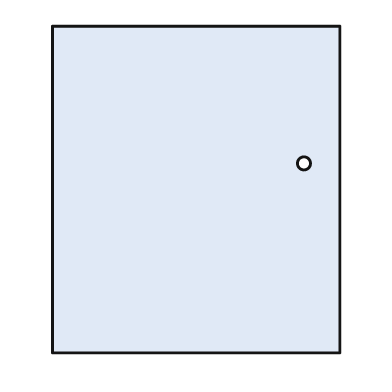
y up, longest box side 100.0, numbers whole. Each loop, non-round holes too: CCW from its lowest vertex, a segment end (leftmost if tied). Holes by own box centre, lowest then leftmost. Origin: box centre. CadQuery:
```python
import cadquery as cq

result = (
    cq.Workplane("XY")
    .moveTo(-44.0, -50.0)
    .lineTo(44.0, -50.0)
    .lineTo(44.0, 50.0)
    .lineTo(-44.0, 50.0)
    .close()
    .moveTo(33.0, 8.0)
    .circle(2.0)
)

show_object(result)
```